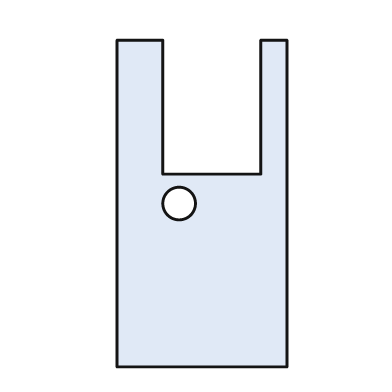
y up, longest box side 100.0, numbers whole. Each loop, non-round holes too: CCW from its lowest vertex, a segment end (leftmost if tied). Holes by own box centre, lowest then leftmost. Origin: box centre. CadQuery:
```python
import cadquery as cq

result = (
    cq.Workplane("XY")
    .moveTo(-26.0, -50.0)
    .lineTo(26.0, -50.0)
    .lineTo(26.0, 50.0)
    .lineTo(18.0, 50.0)
    .lineTo(18.0, 9.0)
    .lineTo(-12.0, 9.0)
    .lineTo(-12.0, 50.0)
    .lineTo(-26.0, 50.0)
    .close()
    .moveTo(-7.0, 0.0)
    .circle(5.0)
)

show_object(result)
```